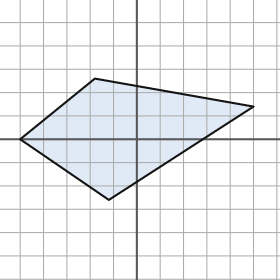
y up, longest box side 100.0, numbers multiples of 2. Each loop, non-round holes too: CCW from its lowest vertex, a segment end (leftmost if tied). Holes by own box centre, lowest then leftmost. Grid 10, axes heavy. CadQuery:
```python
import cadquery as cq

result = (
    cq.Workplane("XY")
    .moveTo(-12.0, -26.0)
    .lineTo(50.0, 14.0)
    .lineTo(-18.0, 26.0)
    .lineTo(-50.0, 0.0)
    .close()
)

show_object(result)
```